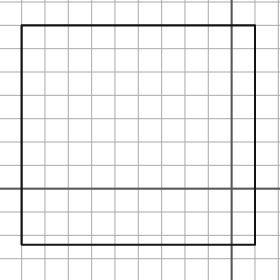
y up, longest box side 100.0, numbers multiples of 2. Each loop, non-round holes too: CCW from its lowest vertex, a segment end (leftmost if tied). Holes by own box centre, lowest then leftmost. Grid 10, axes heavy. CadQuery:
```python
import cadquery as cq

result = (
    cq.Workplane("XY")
    .moveTo(-90.0, -24.0)
    .lineTo(10.0, -24.0)
    .lineTo(10.0, 70.0)
    .lineTo(-90.0, 70.0)
    .close()
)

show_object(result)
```